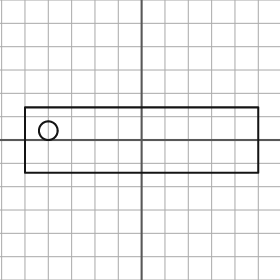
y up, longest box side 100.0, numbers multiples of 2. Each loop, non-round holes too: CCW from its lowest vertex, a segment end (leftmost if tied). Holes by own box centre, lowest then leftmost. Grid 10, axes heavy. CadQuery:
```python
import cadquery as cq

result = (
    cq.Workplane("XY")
    .moveTo(-50.0, -14.0)
    .lineTo(50.0, -14.0)
    .lineTo(50.0, 14.0)
    .lineTo(-50.0, 14.0)
    .close()
    .moveTo(-40.0, 4.0)
    .circle(4.0)
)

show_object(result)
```